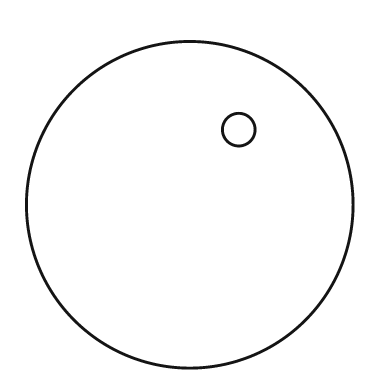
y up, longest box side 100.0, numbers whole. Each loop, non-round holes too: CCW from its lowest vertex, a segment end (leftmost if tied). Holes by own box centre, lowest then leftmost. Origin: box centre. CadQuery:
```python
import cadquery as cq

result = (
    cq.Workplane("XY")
    .moveTo(0.0, 0.0)
    .circle(50.0)
    .moveTo(15.0, 23.0)
    .circle(5.0)
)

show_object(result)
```